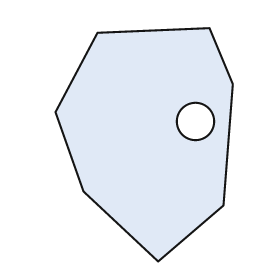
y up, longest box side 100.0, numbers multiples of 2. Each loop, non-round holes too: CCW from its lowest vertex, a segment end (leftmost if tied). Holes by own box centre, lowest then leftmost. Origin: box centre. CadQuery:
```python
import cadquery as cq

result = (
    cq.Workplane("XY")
    .moveTo(6.0, -50.0)
    .lineTo(34.0, -26.0)
    .lineTo(38.0, 26.0)
    .lineTo(28.0, 50.0)
    .lineTo(-20.0, 48.0)
    .lineTo(-38.0, 14.0)
    .lineTo(-26.0, -20.0)
    .close()
    .moveTo(22.0, 10.0)
    .circle(8.0)
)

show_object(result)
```